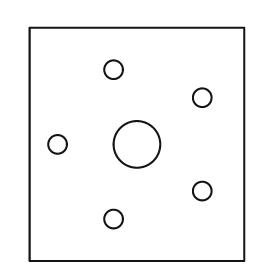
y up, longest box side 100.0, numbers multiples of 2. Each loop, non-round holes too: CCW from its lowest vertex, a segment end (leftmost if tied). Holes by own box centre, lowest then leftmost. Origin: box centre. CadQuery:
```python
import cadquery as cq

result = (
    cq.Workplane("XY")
    .moveTo(-46.0, -50.0)
    .lineTo(46.0, -50.0)
    .lineTo(46.0, 50.0)
    .lineTo(-46.0, 50.0)
    .close()
    .moveTo(-10.0, -32.0)
    .circle(4.0)
    .moveTo(28.0, -20.0)
    .circle(4.0)
    .moveTo(-34.0, 0.0)
    .circle(4.0)
    .moveTo(0.0, 0.0)
    .circle(10.0)
    .moveTo(28.0, 20.0)
    .circle(4.0)
    .moveTo(-10.0, 32.0)
    .circle(4.0)
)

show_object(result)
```